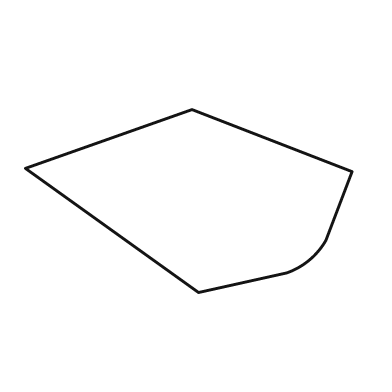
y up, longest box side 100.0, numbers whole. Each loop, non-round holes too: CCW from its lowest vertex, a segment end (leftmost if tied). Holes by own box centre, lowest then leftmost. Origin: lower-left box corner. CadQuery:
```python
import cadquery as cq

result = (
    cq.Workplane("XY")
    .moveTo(53.0, 0.0)
    .lineTo(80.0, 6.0)
    .threePointArc((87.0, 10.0), (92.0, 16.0))
    .lineTo(100.0, 37.0)
    .lineTo(51.0, 56.0)
    .lineTo(0.0, 38.0)
    .close()
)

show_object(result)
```